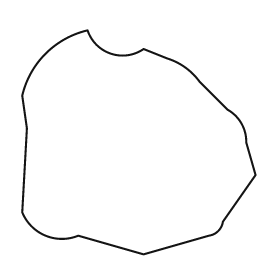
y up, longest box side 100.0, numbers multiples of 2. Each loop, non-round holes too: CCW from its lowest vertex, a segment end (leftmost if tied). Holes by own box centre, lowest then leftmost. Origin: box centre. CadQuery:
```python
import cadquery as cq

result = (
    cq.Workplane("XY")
    .moveTo(2.0, -48.0)
    .lineTo(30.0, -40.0)
    .threePointArc((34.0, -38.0), (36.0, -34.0))
    .lineTo(50.0, -14.0)
    .lineTo(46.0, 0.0)
    .threePointArc((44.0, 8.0), (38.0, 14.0))
    .lineTo(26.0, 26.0)
    .threePointArc((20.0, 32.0), (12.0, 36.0))
    .lineTo(2.0, 40.0)
    .threePointArc((-12.0, 38.0), (-22.0, 48.0))
    .threePointArc((-40.0, 38.0), (-50.0, 20.0))
    .lineTo(-48.0, 6.0)
    .lineTo(-50.0, -30.0)
    .threePointArc((-40.0, -40.0), (-26.0, -40.0))
    .close()
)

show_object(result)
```